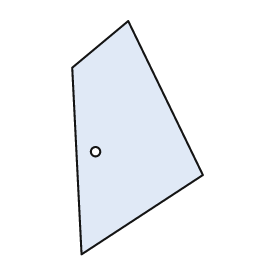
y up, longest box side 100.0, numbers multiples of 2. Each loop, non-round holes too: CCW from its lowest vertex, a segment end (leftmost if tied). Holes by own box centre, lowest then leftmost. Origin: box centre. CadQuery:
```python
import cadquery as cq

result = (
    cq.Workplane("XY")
    .moveTo(-24.0, -50.0)
    .lineTo(28.0, -16.0)
    .lineTo(-4.0, 50.0)
    .lineTo(-28.0, 30.0)
    .close()
    .moveTo(-18.0, -6.0)
    .circle(2.0)
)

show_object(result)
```